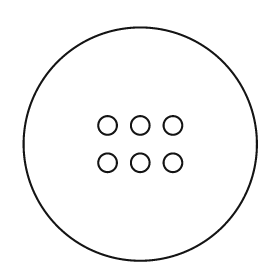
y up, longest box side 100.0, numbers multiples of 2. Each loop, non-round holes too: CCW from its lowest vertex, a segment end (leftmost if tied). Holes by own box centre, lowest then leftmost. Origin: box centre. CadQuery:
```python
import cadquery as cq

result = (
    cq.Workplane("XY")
    .moveTo(0.0, 0.0)
    .circle(50.0)
    .moveTo(-14.0, -8.0)
    .circle(4.0)
    .moveTo(0.0, -8.0)
    .circle(4.0)
    .moveTo(14.0, -8.0)
    .circle(4.0)
    .moveTo(-14.0, 8.0)
    .circle(4.0)
    .moveTo(0.0, 8.0)
    .circle(4.0)
    .moveTo(14.0, 8.0)
    .circle(4.0)
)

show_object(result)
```